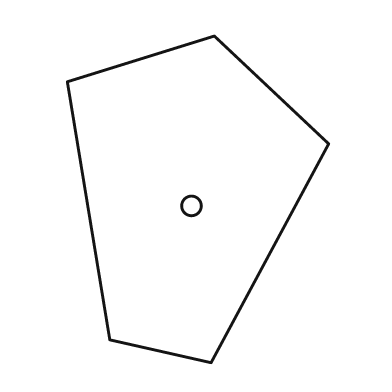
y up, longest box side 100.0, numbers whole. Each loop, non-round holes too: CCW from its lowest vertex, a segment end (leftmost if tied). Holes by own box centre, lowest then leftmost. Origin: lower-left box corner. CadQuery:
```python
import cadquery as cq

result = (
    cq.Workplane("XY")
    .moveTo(44.0, 0.0)
    .lineTo(80.0, 67.0)
    .lineTo(45.0, 100.0)
    .lineTo(0.0, 86.0)
    .lineTo(13.0, 7.0)
    .close()
    .moveTo(38.0, 48.0)
    .circle(3.0)
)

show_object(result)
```